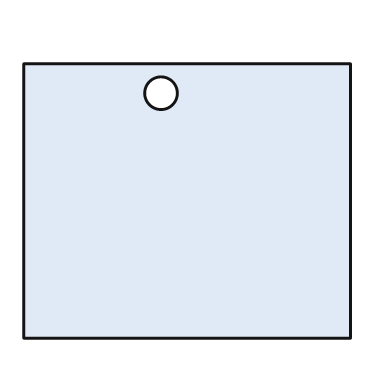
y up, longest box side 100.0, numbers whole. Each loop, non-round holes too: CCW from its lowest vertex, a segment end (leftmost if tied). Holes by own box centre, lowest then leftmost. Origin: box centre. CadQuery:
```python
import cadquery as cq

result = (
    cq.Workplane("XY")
    .moveTo(-50.0, -42.0)
    .lineTo(50.0, -42.0)
    .lineTo(50.0, 42.0)
    .lineTo(-50.0, 42.0)
    .close()
    .moveTo(-8.0, 33.0)
    .circle(5.0)
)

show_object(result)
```